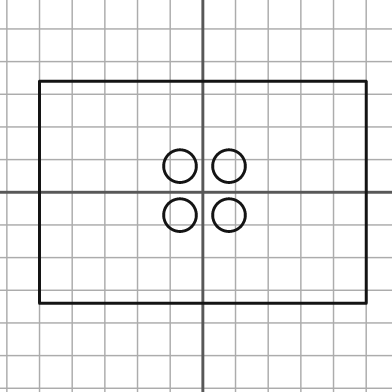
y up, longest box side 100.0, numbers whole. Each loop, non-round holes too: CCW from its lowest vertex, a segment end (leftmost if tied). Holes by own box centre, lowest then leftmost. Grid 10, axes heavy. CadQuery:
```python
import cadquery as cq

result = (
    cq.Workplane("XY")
    .moveTo(-50.0, -34.0)
    .lineTo(50.0, -34.0)
    .lineTo(50.0, 34.0)
    .lineTo(-50.0, 34.0)
    .close()
    .moveTo(-7.0, -7.0)
    .circle(5.0)
    .moveTo(8.0, -7.0)
    .circle(5.0)
    .moveTo(-7.0, 8.0)
    .circle(5.0)
    .moveTo(8.0, 8.0)
    .circle(5.0)
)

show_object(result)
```